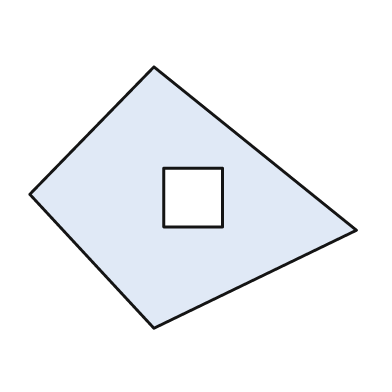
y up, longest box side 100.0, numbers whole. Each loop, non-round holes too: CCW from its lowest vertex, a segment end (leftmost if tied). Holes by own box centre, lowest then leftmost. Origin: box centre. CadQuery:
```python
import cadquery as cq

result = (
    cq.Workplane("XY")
    .moveTo(-12.0, -40.0)
    .lineTo(50.0, -10.0)
    .lineTo(-12.0, 40.0)
    .lineTo(-50.0, 1.0)
    .close()
    .moveTo(-9.0, -9.0)
    .lineTo(9.0, -9.0)
    .lineTo(9.0, 9.0)
    .lineTo(-9.0, 9.0)
    .close()
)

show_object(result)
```